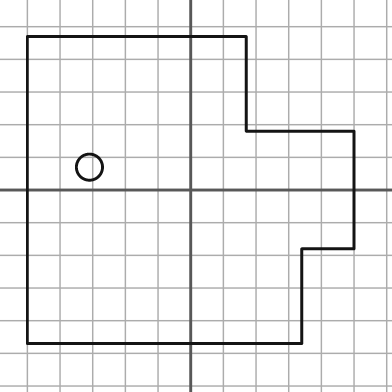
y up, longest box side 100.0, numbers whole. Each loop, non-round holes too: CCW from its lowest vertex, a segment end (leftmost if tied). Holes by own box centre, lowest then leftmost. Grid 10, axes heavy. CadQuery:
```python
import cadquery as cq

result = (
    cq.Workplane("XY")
    .moveTo(-50.0, -47.0)
    .lineTo(34.0, -47.0)
    .lineTo(34.0, -18.0)
    .lineTo(50.0, -18.0)
    .lineTo(50.0, 18.0)
    .lineTo(17.0, 18.0)
    .lineTo(17.0, 47.0)
    .lineTo(-50.0, 47.0)
    .close()
    .moveTo(-31.0, 7.0)
    .circle(4.0)
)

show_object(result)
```